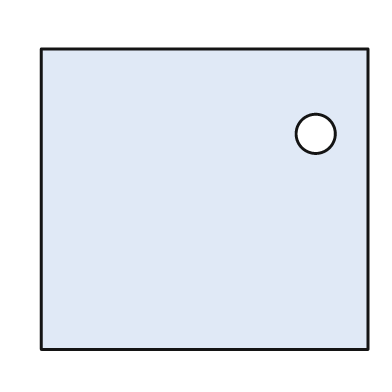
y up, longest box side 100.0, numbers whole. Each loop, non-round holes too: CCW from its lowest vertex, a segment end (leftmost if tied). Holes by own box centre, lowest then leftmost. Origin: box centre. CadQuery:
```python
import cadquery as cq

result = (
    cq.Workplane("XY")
    .moveTo(-50.0, -46.0)
    .lineTo(50.0, -46.0)
    .lineTo(50.0, 46.0)
    .lineTo(-50.0, 46.0)
    .close()
    .moveTo(34.0, 20.0)
    .circle(6.0)
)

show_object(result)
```